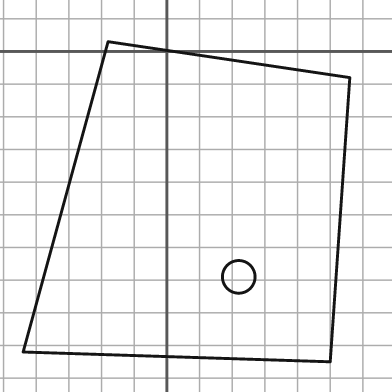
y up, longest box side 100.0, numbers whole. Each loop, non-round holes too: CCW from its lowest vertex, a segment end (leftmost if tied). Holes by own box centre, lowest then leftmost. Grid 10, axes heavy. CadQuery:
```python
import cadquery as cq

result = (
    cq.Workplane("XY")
    .moveTo(50.0, -95.0)
    .lineTo(56.0, -8.0)
    .lineTo(-18.0, 3.0)
    .lineTo(-44.0, -92.0)
    .close()
    .moveTo(22.0, -69.0)
    .circle(5.0)
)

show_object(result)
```